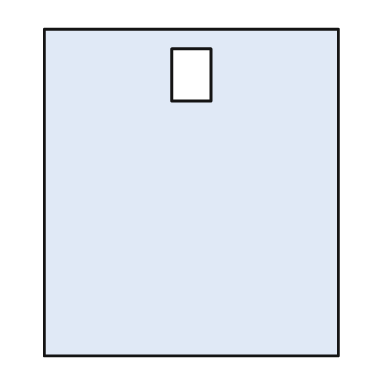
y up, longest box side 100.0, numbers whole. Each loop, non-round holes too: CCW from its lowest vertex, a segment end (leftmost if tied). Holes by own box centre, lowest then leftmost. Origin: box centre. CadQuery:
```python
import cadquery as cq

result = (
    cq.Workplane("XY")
    .moveTo(-45.0, -50.0)
    .lineTo(45.0, -50.0)
    .lineTo(45.0, 50.0)
    .lineTo(-45.0, 50.0)
    .close()
    .moveTo(-6.0, 28.0)
    .lineTo(6.0, 28.0)
    .lineTo(6.0, 44.0)
    .lineTo(-6.0, 44.0)
    .close()
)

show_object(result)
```